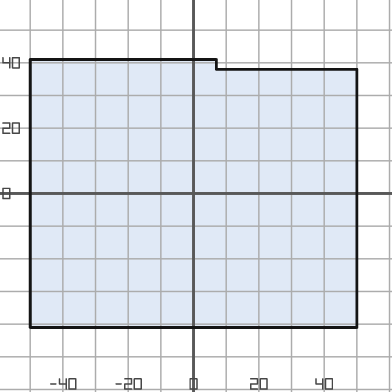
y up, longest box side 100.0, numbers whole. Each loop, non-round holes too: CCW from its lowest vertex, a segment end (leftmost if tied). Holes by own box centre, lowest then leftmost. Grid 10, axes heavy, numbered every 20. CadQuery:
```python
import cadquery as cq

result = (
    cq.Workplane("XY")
    .moveTo(-50.0, -41.0)
    .lineTo(50.0, -41.0)
    .lineTo(50.0, 38.0)
    .lineTo(7.0, 38.0)
    .lineTo(7.0, 41.0)
    .lineTo(-50.0, 41.0)
    .close()
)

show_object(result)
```